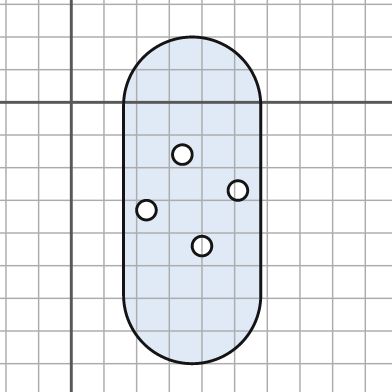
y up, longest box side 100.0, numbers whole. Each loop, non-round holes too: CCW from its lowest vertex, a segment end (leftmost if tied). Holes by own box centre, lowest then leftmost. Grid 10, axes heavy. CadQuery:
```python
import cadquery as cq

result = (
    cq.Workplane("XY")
    .moveTo(16.0, -59.0)
    .threePointArc((37.0, -80.0), (58.0, -59.0))
    .lineTo(58.0, -1.0)
    .threePointArc((37.0, 20.0), (16.0, -1.0))
    .close()
    .moveTo(40.0, -44.0)
    .circle(3.0)
    .moveTo(23.0, -33.0)
    .circle(3.0)
    .moveTo(51.0, -27.0)
    .circle(3.0)
    .moveTo(34.0, -16.0)
    .circle(3.0)
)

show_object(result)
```